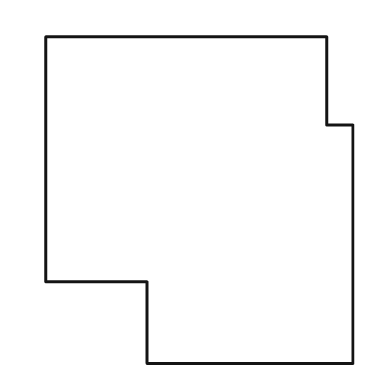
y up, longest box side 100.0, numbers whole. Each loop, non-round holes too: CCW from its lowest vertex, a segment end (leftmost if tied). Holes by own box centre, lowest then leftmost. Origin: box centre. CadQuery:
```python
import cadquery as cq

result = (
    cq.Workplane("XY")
    .moveTo(-16.0, -50.0)
    .lineTo(47.0, -50.0)
    .lineTo(47.0, 23.0)
    .lineTo(39.0, 23.0)
    .lineTo(39.0, 50.0)
    .lineTo(-47.0, 50.0)
    .lineTo(-47.0, -25.0)
    .lineTo(-16.0, -25.0)
    .close()
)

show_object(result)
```